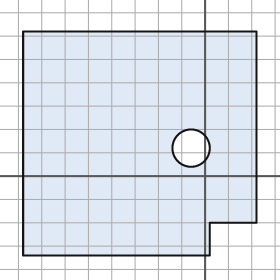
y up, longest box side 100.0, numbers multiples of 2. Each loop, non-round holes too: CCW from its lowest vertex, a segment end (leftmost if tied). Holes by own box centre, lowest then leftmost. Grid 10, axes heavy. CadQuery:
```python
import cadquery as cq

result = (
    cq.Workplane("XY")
    .moveTo(-78.0, -34.0)
    .lineTo(2.0, -34.0)
    .lineTo(2.0, -20.0)
    .lineTo(22.0, -20.0)
    .lineTo(22.0, 62.0)
    .lineTo(-78.0, 62.0)
    .close()
    .moveTo(-6.0, 12.0)
    .circle(8.0)
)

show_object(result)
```